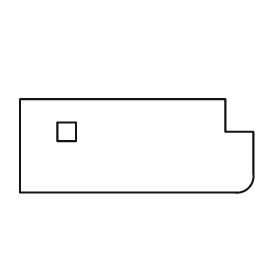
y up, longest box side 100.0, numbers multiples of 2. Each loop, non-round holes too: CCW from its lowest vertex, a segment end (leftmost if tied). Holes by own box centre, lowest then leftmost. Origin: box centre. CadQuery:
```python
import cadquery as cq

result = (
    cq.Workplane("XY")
    .moveTo(-50.0, -20.0)
    .lineTo(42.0, -20.0)
    .threePointArc((48.0, -18.0), (50.0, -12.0))
    .lineTo(50.0, 6.0)
    .lineTo(38.0, 6.0)
    .lineTo(38.0, 20.0)
    .lineTo(-50.0, 20.0)
    .close()
    .moveTo(-34.0, 2.0)
    .lineTo(-26.0, 2.0)
    .lineTo(-26.0, 10.0)
    .lineTo(-34.0, 10.0)
    .close()
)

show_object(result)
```